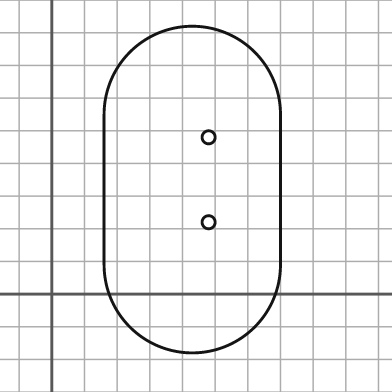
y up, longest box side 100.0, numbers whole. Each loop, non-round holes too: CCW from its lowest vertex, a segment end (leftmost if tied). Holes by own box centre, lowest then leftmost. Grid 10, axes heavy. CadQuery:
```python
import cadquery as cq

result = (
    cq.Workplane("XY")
    .moveTo(16.0, 9.0)
    .threePointArc((43.0, -18.0), (70.0, 9.0))
    .lineTo(70.0, 55.0)
    .threePointArc((43.0, 82.0), (16.0, 55.0))
    .close()
    .moveTo(48.0, 22.0)
    .circle(2.0)
    .moveTo(48.0, 48.0)
    .circle(2.0)
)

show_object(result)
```